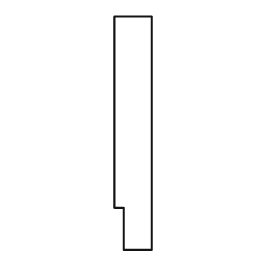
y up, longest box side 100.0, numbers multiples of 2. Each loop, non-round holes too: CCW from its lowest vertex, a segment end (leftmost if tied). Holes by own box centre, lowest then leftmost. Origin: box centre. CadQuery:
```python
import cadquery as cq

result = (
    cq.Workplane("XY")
    .moveTo(-4.0, -50.0)
    .lineTo(8.0, -50.0)
    .lineTo(8.0, 50.0)
    .lineTo(-8.0, 50.0)
    .lineTo(-8.0, -32.0)
    .lineTo(-4.0, -32.0)
    .close()
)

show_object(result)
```